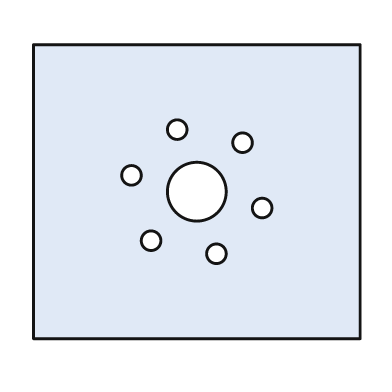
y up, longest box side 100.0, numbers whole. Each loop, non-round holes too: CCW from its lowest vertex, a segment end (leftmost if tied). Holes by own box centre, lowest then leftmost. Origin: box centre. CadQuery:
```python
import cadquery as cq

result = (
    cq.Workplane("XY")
    .moveTo(-50.0, -45.0)
    .lineTo(50.0, -45.0)
    .lineTo(50.0, 45.0)
    .lineTo(-50.0, 45.0)
    .close()
    .moveTo(6.0, -19.0)
    .circle(3.0)
    .moveTo(-14.0, -15.0)
    .circle(3.0)
    .moveTo(20.0, -5.0)
    .circle(3.0)
    .moveTo(0.0, 0.0)
    .circle(9.0)
    .moveTo(-20.0, 5.0)
    .circle(3.0)
    .moveTo(14.0, 15.0)
    .circle(3.0)
    .moveTo(-6.0, 19.0)
    .circle(3.0)
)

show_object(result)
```